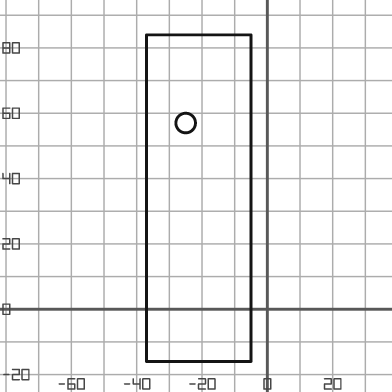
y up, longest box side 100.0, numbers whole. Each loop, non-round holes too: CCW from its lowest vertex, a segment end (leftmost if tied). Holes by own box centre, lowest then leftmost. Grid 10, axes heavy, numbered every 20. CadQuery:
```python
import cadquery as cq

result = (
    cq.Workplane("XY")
    .moveTo(-37.0, -16.0)
    .lineTo(-5.0, -16.0)
    .lineTo(-5.0, 84.0)
    .lineTo(-37.0, 84.0)
    .close()
    .moveTo(-25.0, 57.0)
    .circle(3.0)
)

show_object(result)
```